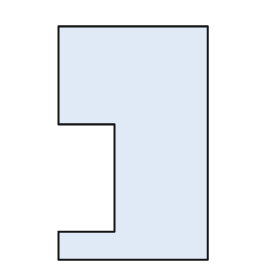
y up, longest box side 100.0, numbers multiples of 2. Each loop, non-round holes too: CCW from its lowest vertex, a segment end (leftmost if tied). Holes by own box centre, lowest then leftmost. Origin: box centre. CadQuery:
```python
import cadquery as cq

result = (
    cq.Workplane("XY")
    .moveTo(-32.0, -50.0)
    .lineTo(32.0, -50.0)
    .lineTo(32.0, 50.0)
    .lineTo(-32.0, 50.0)
    .lineTo(-32.0, 8.0)
    .lineTo(-8.0, 8.0)
    .lineTo(-8.0, -38.0)
    .lineTo(-32.0, -38.0)
    .close()
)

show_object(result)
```